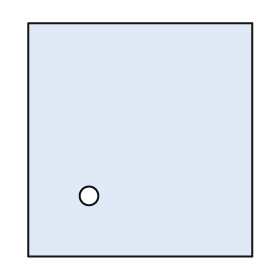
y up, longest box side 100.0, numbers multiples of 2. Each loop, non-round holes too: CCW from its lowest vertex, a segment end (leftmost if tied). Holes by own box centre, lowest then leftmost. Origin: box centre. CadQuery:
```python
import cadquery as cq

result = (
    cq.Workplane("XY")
    .moveTo(-48.0, -50.0)
    .lineTo(48.0, -50.0)
    .lineTo(48.0, 50.0)
    .lineTo(-48.0, 50.0)
    .close()
    .moveTo(-22.0, -24.0)
    .circle(4.0)
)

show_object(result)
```